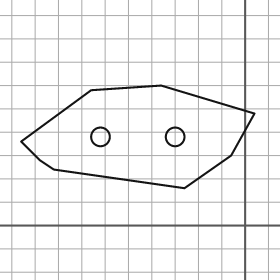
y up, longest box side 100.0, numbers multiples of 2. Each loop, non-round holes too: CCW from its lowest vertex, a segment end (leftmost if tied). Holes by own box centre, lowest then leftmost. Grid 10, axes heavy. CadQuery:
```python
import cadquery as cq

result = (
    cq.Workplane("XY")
    .moveTo(-26.0, 16.0)
    .lineTo(-6.0, 30.0)
    .lineTo(4.0, 48.0)
    .lineTo(-36.0, 60.0)
    .lineTo(-66.0, 58.0)
    .lineTo(-96.0, 36.0)
    .lineTo(-88.0, 28.0)
    .lineTo(-82.0, 24.0)
    .close()
    .moveTo(-62.0, 38.0)
    .circle(4.0)
    .moveTo(-30.0, 38.0)
    .circle(4.0)
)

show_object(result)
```